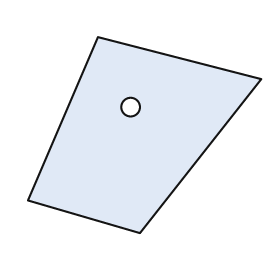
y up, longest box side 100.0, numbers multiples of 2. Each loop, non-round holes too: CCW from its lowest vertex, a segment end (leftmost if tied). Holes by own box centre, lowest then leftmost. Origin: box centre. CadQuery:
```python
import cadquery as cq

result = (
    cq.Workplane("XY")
    .moveTo(-2.0, -42.0)
    .lineTo(50.0, 24.0)
    .lineTo(-20.0, 42.0)
    .lineTo(-50.0, -28.0)
    .close()
    .moveTo(-6.0, 12.0)
    .circle(4.0)
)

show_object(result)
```